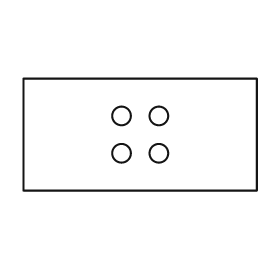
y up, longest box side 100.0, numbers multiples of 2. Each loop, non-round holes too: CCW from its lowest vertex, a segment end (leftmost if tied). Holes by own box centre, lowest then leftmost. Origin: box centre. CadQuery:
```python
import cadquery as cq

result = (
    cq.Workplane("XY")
    .moveTo(-50.0, -24.0)
    .lineTo(50.0, -24.0)
    .lineTo(50.0, 24.0)
    .lineTo(-50.0, 24.0)
    .close()
    .moveTo(-8.0, -8.0)
    .circle(4.0)
    .moveTo(8.0, -8.0)
    .circle(4.0)
    .moveTo(-8.0, 8.0)
    .circle(4.0)
    .moveTo(8.0, 8.0)
    .circle(4.0)
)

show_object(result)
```